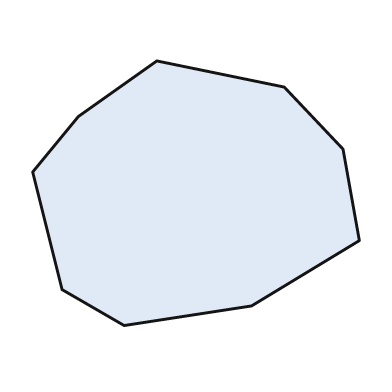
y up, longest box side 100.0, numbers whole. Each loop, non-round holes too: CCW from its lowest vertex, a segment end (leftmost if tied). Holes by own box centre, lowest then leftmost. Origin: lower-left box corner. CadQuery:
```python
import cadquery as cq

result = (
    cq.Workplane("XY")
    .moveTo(28.0, 0.0)
    .lineTo(67.0, 6.0)
    .lineTo(100.0, 26.0)
    .lineTo(95.0, 54.0)
    .lineTo(77.0, 73.0)
    .lineTo(38.0, 81.0)
    .lineTo(14.0, 64.0)
    .lineTo(0.0, 47.0)
    .lineTo(9.0, 11.0)
    .close()
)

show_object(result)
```